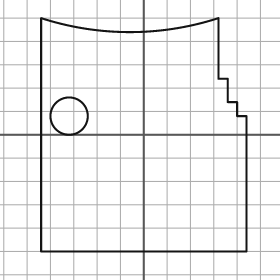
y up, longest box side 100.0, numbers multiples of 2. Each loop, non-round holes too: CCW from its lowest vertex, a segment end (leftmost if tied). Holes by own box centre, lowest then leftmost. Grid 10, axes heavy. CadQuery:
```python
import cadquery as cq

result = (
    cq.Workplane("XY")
    .moveTo(-44.0, -50.0)
    .lineTo(44.0, -50.0)
    .lineTo(44.0, 8.0)
    .lineTo(40.0, 8.0)
    .lineTo(40.0, 14.0)
    .lineTo(36.0, 14.0)
    .lineTo(36.0, 24.0)
    .lineTo(32.0, 24.0)
    .lineTo(32.0, 50.0)
    .threePointArc((-6.0, 44.0), (-44.0, 50.0))
    .close()
    .moveTo(-32.0, 8.0)
    .circle(8.0)
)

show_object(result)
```